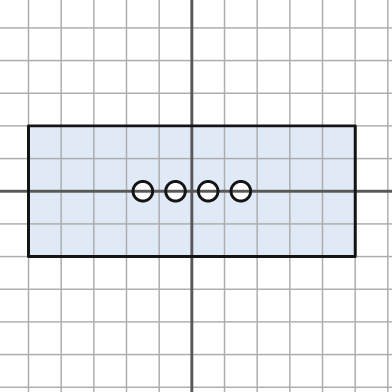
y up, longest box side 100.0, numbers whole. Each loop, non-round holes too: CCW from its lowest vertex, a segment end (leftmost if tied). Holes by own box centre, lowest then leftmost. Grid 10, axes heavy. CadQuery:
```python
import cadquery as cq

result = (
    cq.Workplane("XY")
    .moveTo(-50.0, -20.0)
    .lineTo(50.0, -20.0)
    .lineTo(50.0, 20.0)
    .lineTo(-50.0, 20.0)
    .close()
    .moveTo(-15.0, 0.0)
    .circle(3.0)
    .moveTo(-5.0, 0.0)
    .circle(3.0)
    .moveTo(5.0, 0.0)
    .circle(3.0)
    .moveTo(15.0, 0.0)
    .circle(3.0)
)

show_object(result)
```